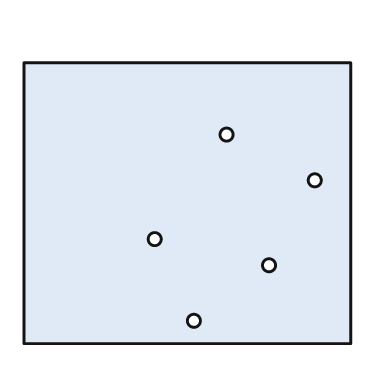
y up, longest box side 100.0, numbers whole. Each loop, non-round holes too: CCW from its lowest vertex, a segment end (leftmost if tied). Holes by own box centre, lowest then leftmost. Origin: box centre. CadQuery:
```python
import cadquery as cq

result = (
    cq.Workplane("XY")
    .moveTo(-50.0, -43.0)
    .lineTo(50.0, -43.0)
    .lineTo(50.0, 43.0)
    .lineTo(-50.0, 43.0)
    .close()
    .moveTo(2.0, -36.0)
    .circle(2.0)
    .moveTo(25.0, -19.0)
    .circle(2.0)
    .moveTo(-10.0, -11.0)
    .circle(2.0)
    .moveTo(39.0, 7.0)
    .circle(2.0)
    .moveTo(12.0, 21.0)
    .circle(2.0)
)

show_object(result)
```